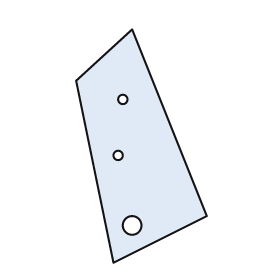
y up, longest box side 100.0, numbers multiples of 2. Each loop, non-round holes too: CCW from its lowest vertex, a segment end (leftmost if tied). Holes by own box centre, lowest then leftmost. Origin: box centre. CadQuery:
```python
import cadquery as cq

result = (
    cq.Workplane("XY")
    .moveTo(-12.0, -50.0)
    .lineTo(28.0, -30.0)
    .lineTo(-4.0, 50.0)
    .lineTo(-28.0, 28.0)
    .close()
    .moveTo(-4.0, -34.0)
    .circle(4.0)
    .moveTo(-10.0, -4.0)
    .circle(2.0)
    .moveTo(-8.0, 20.0)
    .circle(2.0)
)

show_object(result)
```